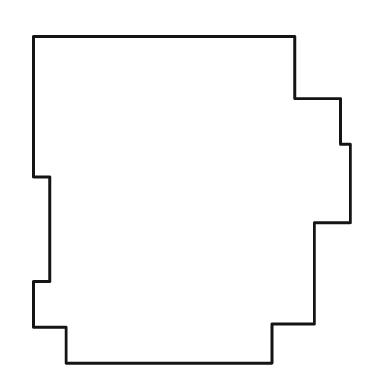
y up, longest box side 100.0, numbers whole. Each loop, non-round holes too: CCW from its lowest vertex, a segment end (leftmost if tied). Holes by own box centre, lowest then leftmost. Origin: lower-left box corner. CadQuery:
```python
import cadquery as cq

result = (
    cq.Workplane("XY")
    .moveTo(10.0, 0.0)
    .lineTo(73.0, 0.0)
    .lineTo(73.0, 12.0)
    .lineTo(86.0, 12.0)
    .lineTo(86.0, 43.0)
    .lineTo(97.0, 43.0)
    .lineTo(97.0, 67.0)
    .lineTo(94.0, 67.0)
    .lineTo(94.0, 81.0)
    .lineTo(80.0, 81.0)
    .lineTo(80.0, 100.0)
    .lineTo(0.0, 100.0)
    .lineTo(0.0, 57.0)
    .lineTo(5.0, 57.0)
    .lineTo(5.0, 25.0)
    .lineTo(0.0, 25.0)
    .lineTo(0.0, 11.0)
    .lineTo(10.0, 11.0)
    .close()
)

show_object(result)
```